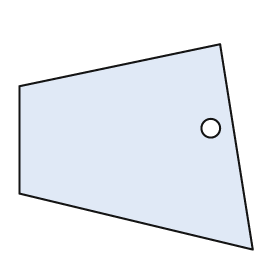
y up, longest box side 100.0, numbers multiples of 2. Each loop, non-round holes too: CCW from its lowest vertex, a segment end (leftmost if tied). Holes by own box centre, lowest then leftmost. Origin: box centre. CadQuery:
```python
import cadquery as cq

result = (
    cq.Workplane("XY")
    .moveTo(50.0, -44.0)
    .lineTo(36.0, 44.0)
    .lineTo(-50.0, 26.0)
    .lineTo(-50.0, -20.0)
    .close()
    .moveTo(32.0, 8.0)
    .circle(4.0)
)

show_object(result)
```